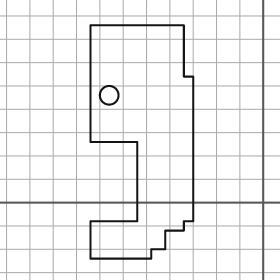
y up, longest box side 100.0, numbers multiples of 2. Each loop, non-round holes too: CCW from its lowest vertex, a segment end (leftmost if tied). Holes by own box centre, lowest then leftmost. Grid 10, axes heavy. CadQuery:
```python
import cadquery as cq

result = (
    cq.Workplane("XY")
    .moveTo(-74.0, -24.0)
    .lineTo(-48.0, -24.0)
    .lineTo(-48.0, -20.0)
    .lineTo(-42.0, -20.0)
    .lineTo(-42.0, -12.0)
    .lineTo(-34.0, -12.0)
    .lineTo(-34.0, -8.0)
    .lineTo(-30.0, -8.0)
    .lineTo(-30.0, 54.0)
    .lineTo(-34.0, 54.0)
    .lineTo(-34.0, 76.0)
    .lineTo(-74.0, 76.0)
    .lineTo(-74.0, 26.0)
    .lineTo(-54.0, 26.0)
    .lineTo(-54.0, -8.0)
    .lineTo(-74.0, -8.0)
    .close()
    .moveTo(-66.0, 46.0)
    .circle(4.0)
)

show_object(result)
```